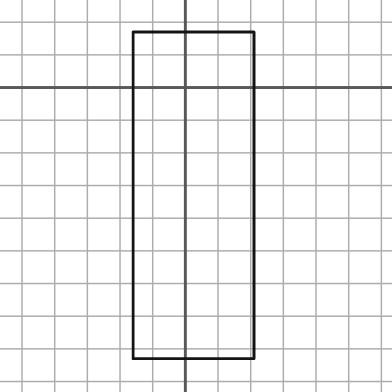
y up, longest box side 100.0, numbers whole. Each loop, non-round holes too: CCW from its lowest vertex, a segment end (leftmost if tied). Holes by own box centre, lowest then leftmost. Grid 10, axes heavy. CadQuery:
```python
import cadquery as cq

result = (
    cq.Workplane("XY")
    .moveTo(-16.0, -83.0)
    .lineTo(21.0, -83.0)
    .lineTo(21.0, 17.0)
    .lineTo(-16.0, 17.0)
    .close()
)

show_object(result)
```